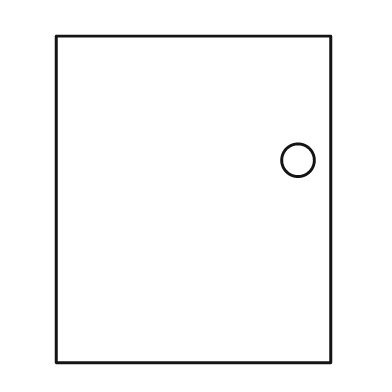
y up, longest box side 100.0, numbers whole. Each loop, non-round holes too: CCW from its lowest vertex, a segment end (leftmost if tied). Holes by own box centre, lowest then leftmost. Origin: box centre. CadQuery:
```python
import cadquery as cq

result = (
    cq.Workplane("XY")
    .moveTo(-42.0, -50.0)
    .lineTo(42.0, -50.0)
    .lineTo(42.0, 50.0)
    .lineTo(-42.0, 50.0)
    .close()
    .moveTo(32.0, 12.0)
    .circle(5.0)
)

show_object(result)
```